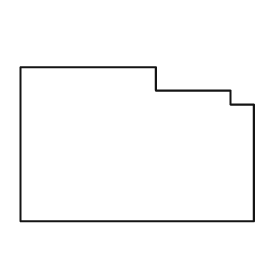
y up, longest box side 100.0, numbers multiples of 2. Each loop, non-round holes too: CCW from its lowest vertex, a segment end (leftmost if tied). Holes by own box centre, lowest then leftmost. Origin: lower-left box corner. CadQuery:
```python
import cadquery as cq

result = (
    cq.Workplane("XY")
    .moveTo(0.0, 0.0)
    .lineTo(100.0, 0.0)
    .lineTo(100.0, 50.0)
    .lineTo(90.0, 50.0)
    .lineTo(90.0, 56.0)
    .lineTo(58.0, 56.0)
    .lineTo(58.0, 66.0)
    .lineTo(0.0, 66.0)
    .close()
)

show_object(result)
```